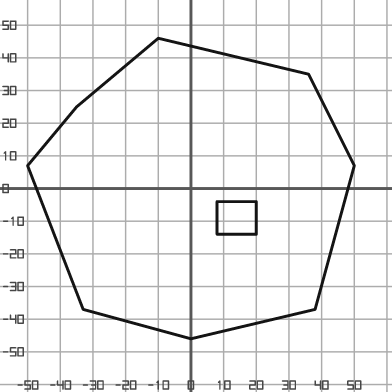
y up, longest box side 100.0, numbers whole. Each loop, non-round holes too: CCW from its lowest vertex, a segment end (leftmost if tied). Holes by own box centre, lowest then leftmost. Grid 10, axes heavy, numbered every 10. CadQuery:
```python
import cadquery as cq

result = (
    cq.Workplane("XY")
    .moveTo(0.0, -46.0)
    .lineTo(38.0, -37.0)
    .lineTo(50.0, 7.0)
    .lineTo(36.0, 35.0)
    .lineTo(-10.0, 46.0)
    .lineTo(-35.0, 25.0)
    .lineTo(-50.0, 7.0)
    .lineTo(-33.0, -37.0)
    .close()
    .moveTo(8.0, -14.0)
    .lineTo(20.0, -14.0)
    .lineTo(20.0, -4.0)
    .lineTo(8.0, -4.0)
    .close()
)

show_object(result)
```